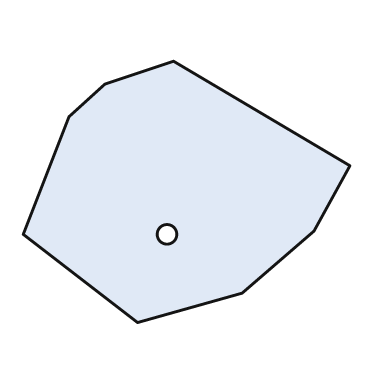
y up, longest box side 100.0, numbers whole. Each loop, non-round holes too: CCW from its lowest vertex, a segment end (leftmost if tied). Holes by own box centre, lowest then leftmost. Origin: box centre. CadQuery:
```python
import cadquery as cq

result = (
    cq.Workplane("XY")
    .moveTo(-15.0, -40.0)
    .lineTo(17.0, -31.0)
    .lineTo(39.0, -12.0)
    .lineTo(50.0, 8.0)
    .lineTo(-4.0, 40.0)
    .lineTo(-25.0, 33.0)
    .lineTo(-36.0, 23.0)
    .lineTo(-50.0, -13.0)
    .close()
    .moveTo(-6.0, -13.0)
    .circle(3.0)
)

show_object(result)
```